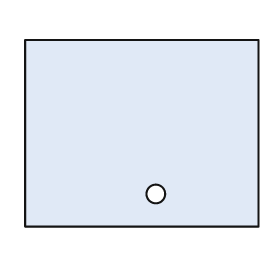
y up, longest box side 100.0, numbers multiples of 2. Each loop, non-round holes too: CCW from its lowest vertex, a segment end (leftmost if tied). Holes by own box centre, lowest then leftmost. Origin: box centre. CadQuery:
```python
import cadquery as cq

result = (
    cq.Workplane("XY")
    .moveTo(-50.0, -40.0)
    .lineTo(50.0, -40.0)
    .lineTo(50.0, 40.0)
    .lineTo(-50.0, 40.0)
    .close()
    .moveTo(6.0, -26.0)
    .circle(4.0)
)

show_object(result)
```